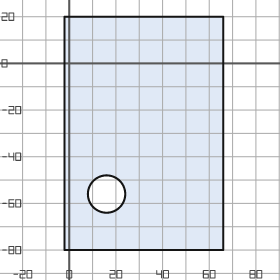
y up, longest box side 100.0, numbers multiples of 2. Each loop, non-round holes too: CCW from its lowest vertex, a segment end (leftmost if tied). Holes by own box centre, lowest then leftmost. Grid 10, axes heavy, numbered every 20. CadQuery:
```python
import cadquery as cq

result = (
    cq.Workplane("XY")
    .moveTo(-2.0, -80.0)
    .lineTo(66.0, -80.0)
    .lineTo(66.0, 20.0)
    .lineTo(-2.0, 20.0)
    .close()
    .moveTo(16.0, -56.0)
    .circle(8.0)
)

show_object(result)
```